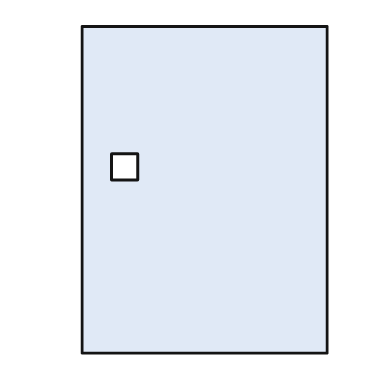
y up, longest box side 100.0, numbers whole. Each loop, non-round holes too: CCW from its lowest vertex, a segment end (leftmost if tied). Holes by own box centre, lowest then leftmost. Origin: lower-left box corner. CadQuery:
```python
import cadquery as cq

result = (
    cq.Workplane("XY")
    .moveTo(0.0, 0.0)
    .lineTo(75.0, 0.0)
    .lineTo(75.0, 100.0)
    .lineTo(0.0, 100.0)
    .close()
    .moveTo(9.0, 53.0)
    .lineTo(17.0, 53.0)
    .lineTo(17.0, 61.0)
    .lineTo(9.0, 61.0)
    .close()
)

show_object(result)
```